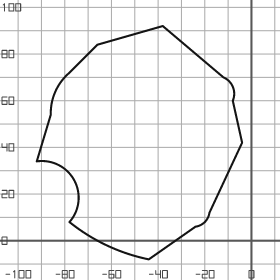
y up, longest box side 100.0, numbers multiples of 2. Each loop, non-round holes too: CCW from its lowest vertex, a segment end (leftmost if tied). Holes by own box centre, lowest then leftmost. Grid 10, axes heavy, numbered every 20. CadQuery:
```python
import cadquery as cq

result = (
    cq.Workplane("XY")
    .moveTo(-44.0, -8.0)
    .lineTo(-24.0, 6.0)
    .threePointArc((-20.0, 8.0), (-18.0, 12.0))
    .lineTo(-4.0, 42.0)
    .lineTo(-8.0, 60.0)
    .threePointArc((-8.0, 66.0), (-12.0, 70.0))
    .lineTo(-38.0, 92.0)
    .lineTo(-66.0, 84.0)
    .lineTo(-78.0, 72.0)
    .threePointArc((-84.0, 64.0), (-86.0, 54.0))
    .lineTo(-92.0, 34.0)
    .threePointArc((-76.0, 26.0), (-78.0, 8.0))
    .threePointArc((-62.0, -2.0), (-44.0, -8.0))
    .close()
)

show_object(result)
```